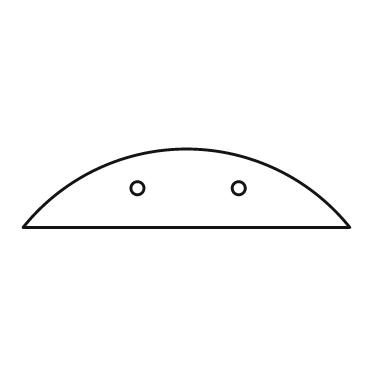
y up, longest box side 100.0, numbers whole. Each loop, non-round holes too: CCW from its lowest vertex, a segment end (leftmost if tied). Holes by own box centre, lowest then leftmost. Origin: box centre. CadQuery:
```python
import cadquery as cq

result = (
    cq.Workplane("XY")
    .moveTo(-50.0, -12.0)
    .lineTo(50.0, -12.0)
    .threePointArc((0.0, 12.0), (-50.0, -12.0))
    .close()
    .moveTo(-15.0, 0.0)
    .circle(2.0)
    .moveTo(16.0, 0.0)
    .circle(2.0)
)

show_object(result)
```